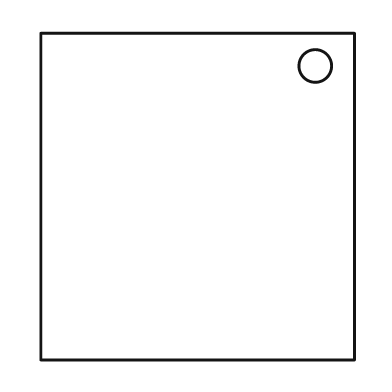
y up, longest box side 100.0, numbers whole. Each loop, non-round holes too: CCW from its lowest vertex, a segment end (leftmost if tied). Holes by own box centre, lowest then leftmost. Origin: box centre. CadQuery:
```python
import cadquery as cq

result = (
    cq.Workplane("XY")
    .moveTo(-48.0, -50.0)
    .lineTo(48.0, -50.0)
    .lineTo(48.0, 50.0)
    .lineTo(-48.0, 50.0)
    .close()
    .moveTo(36.0, 40.0)
    .circle(5.0)
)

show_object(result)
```